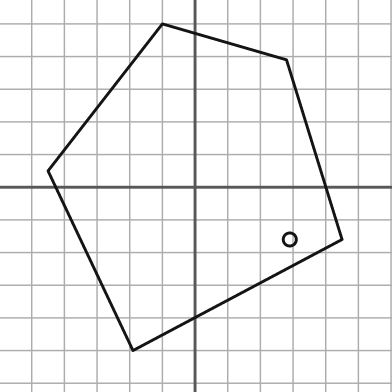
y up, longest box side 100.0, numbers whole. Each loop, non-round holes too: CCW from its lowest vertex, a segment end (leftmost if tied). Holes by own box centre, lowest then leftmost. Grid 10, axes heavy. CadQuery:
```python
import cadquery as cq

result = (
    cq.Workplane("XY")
    .moveTo(-19.0, -50.0)
    .lineTo(45.0, -16.0)
    .lineTo(28.0, 39.0)
    .lineTo(-10.0, 50.0)
    .lineTo(-45.0, 5.0)
    .close()
    .moveTo(29.0, -16.0)
    .circle(2.0)
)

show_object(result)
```